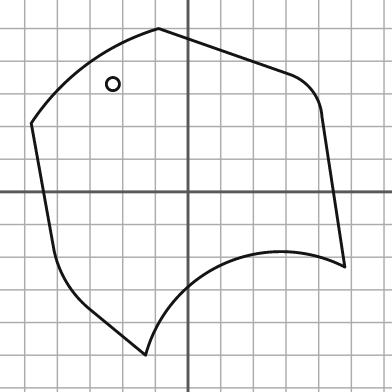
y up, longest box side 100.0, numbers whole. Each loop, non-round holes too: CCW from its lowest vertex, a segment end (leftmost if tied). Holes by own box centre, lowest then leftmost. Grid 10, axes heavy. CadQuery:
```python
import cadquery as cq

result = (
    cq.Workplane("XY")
    .moveTo(-13.0, -50.0)
    .threePointArc((11.0, -22.0), (48.0, -23.0))
    .lineTo(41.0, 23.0)
    .threePointArc((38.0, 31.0), (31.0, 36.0))
    .lineTo(-9.0, 50.0)
    .threePointArc((-31.0, 39.0), (-48.0, 21.0))
    .lineTo(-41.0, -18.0)
    .threePointArc((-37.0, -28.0), (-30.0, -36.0))
    .close()
    .moveTo(-23.0, 33.0)
    .circle(2.0)
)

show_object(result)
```